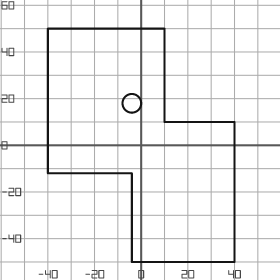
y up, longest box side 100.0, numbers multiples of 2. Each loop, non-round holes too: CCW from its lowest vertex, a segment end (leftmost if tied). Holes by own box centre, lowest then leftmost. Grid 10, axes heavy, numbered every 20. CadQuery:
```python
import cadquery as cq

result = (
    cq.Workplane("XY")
    .moveTo(-4.0, -50.0)
    .lineTo(40.0, -50.0)
    .lineTo(40.0, 10.0)
    .lineTo(10.0, 10.0)
    .lineTo(10.0, 50.0)
    .lineTo(-40.0, 50.0)
    .lineTo(-40.0, -12.0)
    .lineTo(-4.0, -12.0)
    .close()
    .moveTo(-4.0, 18.0)
    .circle(4.0)
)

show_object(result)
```